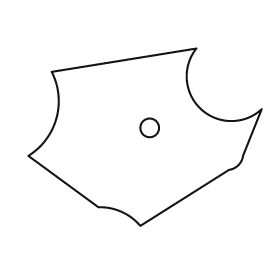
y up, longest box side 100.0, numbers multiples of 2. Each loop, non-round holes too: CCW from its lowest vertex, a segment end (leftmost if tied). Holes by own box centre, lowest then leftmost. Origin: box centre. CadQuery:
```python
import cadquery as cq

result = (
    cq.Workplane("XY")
    .moveTo(-2.0, -38.0)
    .lineTo(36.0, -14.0)
    .threePointArc((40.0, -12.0), (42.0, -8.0))
    .lineTo(50.0, 12.0)
    .threePointArc((24.0, 12.0), (22.0, 38.0))
    .lineTo(-40.0, 28.0)
    .threePointArc((-38.0, 8.0), (-50.0, -8.0))
    .lineTo(-20.0, -30.0)
    .threePointArc((-10.0, -32.0), (-2.0, -38.0))
    .close()
    .moveTo(2.0, 4.0)
    .circle(4.0)
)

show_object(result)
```